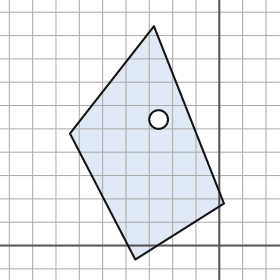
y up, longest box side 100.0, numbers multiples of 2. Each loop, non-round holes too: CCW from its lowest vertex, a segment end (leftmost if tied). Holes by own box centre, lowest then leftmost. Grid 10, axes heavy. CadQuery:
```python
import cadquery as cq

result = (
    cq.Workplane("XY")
    .moveTo(-36.0, -6.0)
    .lineTo(2.0, 18.0)
    .lineTo(-28.0, 94.0)
    .lineTo(-64.0, 48.0)
    .close()
    .moveTo(-26.0, 54.0)
    .circle(4.0)
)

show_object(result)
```